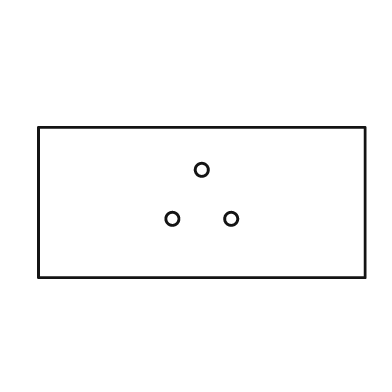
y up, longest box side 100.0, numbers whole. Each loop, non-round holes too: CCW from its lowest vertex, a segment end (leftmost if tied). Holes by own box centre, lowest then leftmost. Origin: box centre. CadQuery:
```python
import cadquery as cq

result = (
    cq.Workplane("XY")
    .moveTo(-50.0, -23.0)
    .lineTo(50.0, -23.0)
    .lineTo(50.0, 23.0)
    .lineTo(-50.0, 23.0)
    .close()
    .moveTo(-9.0, -5.0)
    .circle(2.0)
    .moveTo(9.0, -5.0)
    .circle(2.0)
    .moveTo(0.0, 10.0)
    .circle(2.0)
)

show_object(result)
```